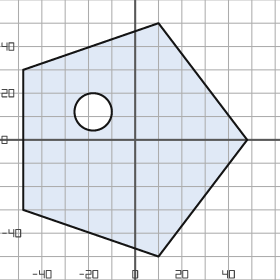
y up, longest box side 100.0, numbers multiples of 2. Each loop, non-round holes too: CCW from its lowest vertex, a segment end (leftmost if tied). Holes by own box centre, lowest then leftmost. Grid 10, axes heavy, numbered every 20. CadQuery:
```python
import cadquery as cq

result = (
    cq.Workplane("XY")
    .moveTo(10.0, -50.0)
    .lineTo(48.0, 0.0)
    .lineTo(10.0, 50.0)
    .lineTo(-48.0, 30.0)
    .lineTo(-48.0, -30.0)
    .close()
    .moveTo(-18.0, 12.0)
    .circle(8.0)
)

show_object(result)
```